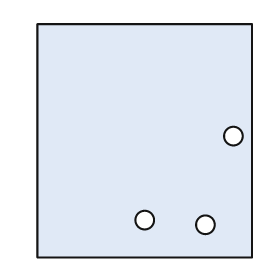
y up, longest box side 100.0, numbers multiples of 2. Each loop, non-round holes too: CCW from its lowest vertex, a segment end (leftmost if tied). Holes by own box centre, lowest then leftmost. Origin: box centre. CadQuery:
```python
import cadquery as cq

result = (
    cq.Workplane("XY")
    .moveTo(-46.0, -50.0)
    .lineTo(46.0, -50.0)
    .lineTo(46.0, 50.0)
    .lineTo(-46.0, 50.0)
    .close()
    .moveTo(26.0, -36.0)
    .circle(4.0)
    .moveTo(0.0, -34.0)
    .circle(4.0)
    .moveTo(38.0, 2.0)
    .circle(4.0)
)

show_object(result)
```